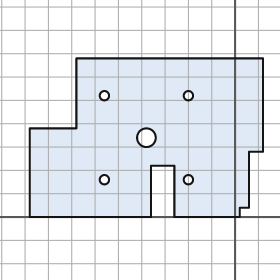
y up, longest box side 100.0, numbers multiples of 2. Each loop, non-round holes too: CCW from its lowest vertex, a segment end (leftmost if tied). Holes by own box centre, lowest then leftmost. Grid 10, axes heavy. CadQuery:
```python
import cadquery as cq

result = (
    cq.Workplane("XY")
    .moveTo(-88.0, 0.0)
    .lineTo(-36.0, 0.0)
    .lineTo(-36.0, 22.0)
    .lineTo(-26.0, 22.0)
    .lineTo(-26.0, 0.0)
    .lineTo(2.0, 0.0)
    .lineTo(2.0, 4.0)
    .lineTo(6.0, 4.0)
    .lineTo(6.0, 28.0)
    .lineTo(12.0, 28.0)
    .lineTo(12.0, 68.0)
    .lineTo(-68.0, 68.0)
    .lineTo(-68.0, 38.0)
    .lineTo(-88.0, 38.0)
    .close()
    .moveTo(-56.0, 16.0)
    .circle(2.0)
    .moveTo(-20.0, 16.0)
    .circle(2.0)
    .moveTo(-38.0, 34.0)
    .circle(4.0)
    .moveTo(-56.0, 52.0)
    .circle(2.0)
    .moveTo(-20.0, 52.0)
    .circle(2.0)
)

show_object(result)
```